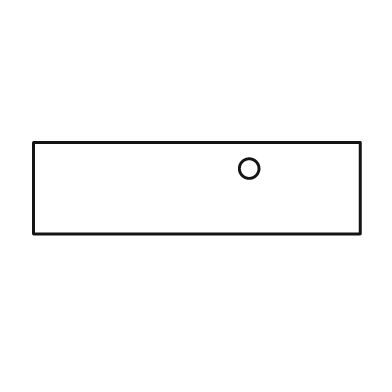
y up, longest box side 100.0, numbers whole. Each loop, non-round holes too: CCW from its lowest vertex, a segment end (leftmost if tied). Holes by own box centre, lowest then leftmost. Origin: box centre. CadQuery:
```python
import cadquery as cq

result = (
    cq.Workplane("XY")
    .moveTo(-50.0, -14.0)
    .lineTo(50.0, -14.0)
    .lineTo(50.0, 14.0)
    .lineTo(-50.0, 14.0)
    .close()
    .moveTo(16.0, 6.0)
    .circle(3.0)
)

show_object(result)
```